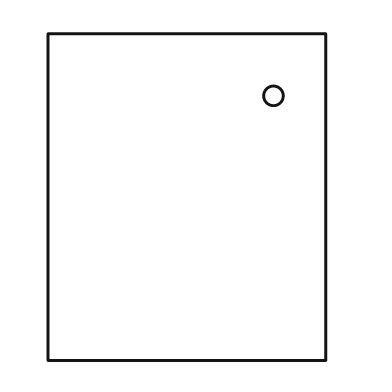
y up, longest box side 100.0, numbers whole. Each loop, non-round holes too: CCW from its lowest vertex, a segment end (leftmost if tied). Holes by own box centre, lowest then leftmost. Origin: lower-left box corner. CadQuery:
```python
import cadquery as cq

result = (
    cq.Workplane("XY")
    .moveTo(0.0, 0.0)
    .lineTo(85.0, 0.0)
    .lineTo(85.0, 100.0)
    .lineTo(0.0, 100.0)
    .close()
    .moveTo(69.0, 81.0)
    .circle(3.0)
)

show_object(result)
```